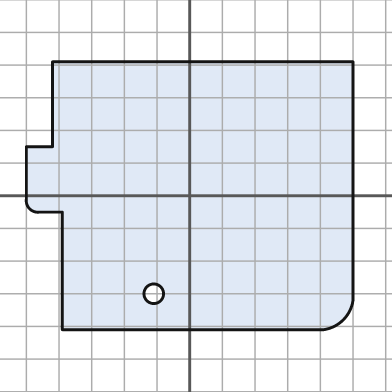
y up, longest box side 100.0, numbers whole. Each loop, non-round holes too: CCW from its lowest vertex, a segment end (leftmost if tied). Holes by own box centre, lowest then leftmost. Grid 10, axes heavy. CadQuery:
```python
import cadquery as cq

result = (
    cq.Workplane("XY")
    .moveTo(-39.0, -41.0)
    .lineTo(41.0, -41.0)
    .threePointArc((47.0, -38.0), (50.0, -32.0))
    .lineTo(50.0, 41.0)
    .lineTo(-42.0, 41.0)
    .lineTo(-42.0, 15.0)
    .lineTo(-50.0, 15.0)
    .lineTo(-50.0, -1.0)
    .threePointArc((-49.0, -4.0), (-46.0, -5.0))
    .lineTo(-39.0, -5.0)
    .close()
    .moveTo(-11.0, -30.0)
    .circle(3.0)
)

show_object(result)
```